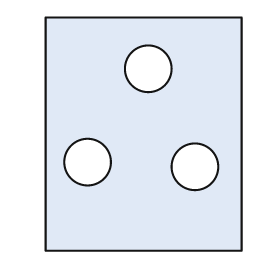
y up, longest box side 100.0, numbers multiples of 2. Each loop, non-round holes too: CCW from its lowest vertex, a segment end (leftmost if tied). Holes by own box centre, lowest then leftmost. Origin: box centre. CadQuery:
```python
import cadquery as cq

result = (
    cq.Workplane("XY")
    .moveTo(-42.0, -50.0)
    .lineTo(42.0, -50.0)
    .lineTo(42.0, 50.0)
    .lineTo(-42.0, 50.0)
    .close()
    .moveTo(22.0, -14.0)
    .circle(10.0)
    .moveTo(-24.0, -12.0)
    .circle(10.0)
    .moveTo(2.0, 28.0)
    .circle(10.0)
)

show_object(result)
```